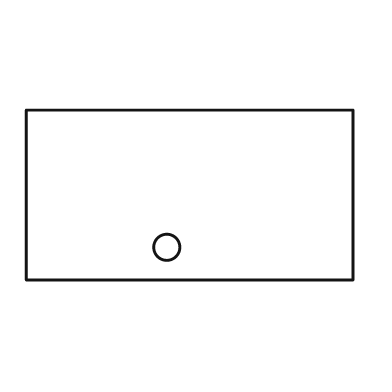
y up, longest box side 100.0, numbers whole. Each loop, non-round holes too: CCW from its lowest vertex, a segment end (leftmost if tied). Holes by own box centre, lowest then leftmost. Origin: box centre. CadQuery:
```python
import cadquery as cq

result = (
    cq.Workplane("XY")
    .moveTo(-50.0, -26.0)
    .lineTo(50.0, -26.0)
    .lineTo(50.0, 26.0)
    .lineTo(-50.0, 26.0)
    .close()
    .moveTo(-7.0, -16.0)
    .circle(4.0)
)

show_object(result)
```